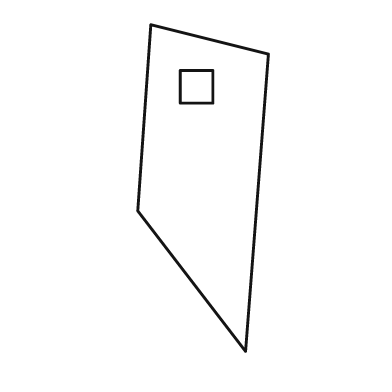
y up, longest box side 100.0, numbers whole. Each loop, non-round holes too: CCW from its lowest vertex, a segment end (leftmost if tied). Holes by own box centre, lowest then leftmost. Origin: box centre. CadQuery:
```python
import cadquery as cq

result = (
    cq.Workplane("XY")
    .moveTo(13.0, -50.0)
    .lineTo(20.0, 41.0)
    .lineTo(-16.0, 50.0)
    .lineTo(-20.0, -7.0)
    .close()
    .moveTo(-7.0, 26.0)
    .lineTo(3.0, 26.0)
    .lineTo(3.0, 36.0)
    .lineTo(-7.0, 36.0)
    .close()
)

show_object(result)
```